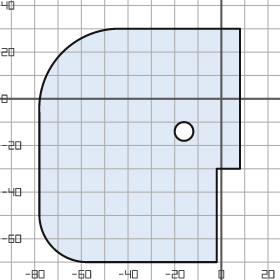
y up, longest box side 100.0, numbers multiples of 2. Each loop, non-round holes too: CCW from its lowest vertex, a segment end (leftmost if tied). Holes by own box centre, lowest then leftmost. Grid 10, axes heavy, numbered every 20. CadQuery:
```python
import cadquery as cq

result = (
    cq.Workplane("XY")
    .moveTo(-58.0, -70.0)
    .lineTo(-2.0, -70.0)
    .lineTo(-2.0, -30.0)
    .lineTo(8.0, -30.0)
    .lineTo(8.0, 30.0)
    .lineTo(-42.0, 30.0)
    .threePointArc((-68.0, 20.0), (-78.0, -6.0))
    .lineTo(-78.0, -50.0)
    .threePointArc((-72.0, -64.0), (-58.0, -70.0))
    .close()
    .moveTo(-16.0, -14.0)
    .circle(4.0)
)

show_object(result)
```